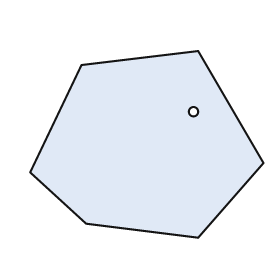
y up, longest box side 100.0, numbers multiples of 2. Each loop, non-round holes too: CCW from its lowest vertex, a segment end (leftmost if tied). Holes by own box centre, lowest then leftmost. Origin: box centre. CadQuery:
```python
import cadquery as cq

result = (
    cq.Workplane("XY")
    .moveTo(22.0, -40.0)
    .lineTo(50.0, -8.0)
    .lineTo(22.0, 40.0)
    .lineTo(-28.0, 34.0)
    .lineTo(-50.0, -12.0)
    .lineTo(-26.0, -34.0)
    .close()
    .moveTo(20.0, 14.0)
    .circle(2.0)
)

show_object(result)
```